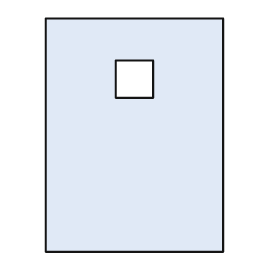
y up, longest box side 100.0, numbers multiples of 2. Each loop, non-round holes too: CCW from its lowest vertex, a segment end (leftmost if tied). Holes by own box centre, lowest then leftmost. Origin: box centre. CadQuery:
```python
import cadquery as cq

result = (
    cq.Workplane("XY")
    .moveTo(-38.0, -50.0)
    .lineTo(38.0, -50.0)
    .lineTo(38.0, 50.0)
    .lineTo(-38.0, 50.0)
    .close()
    .moveTo(-8.0, 16.0)
    .lineTo(8.0, 16.0)
    .lineTo(8.0, 32.0)
    .lineTo(-8.0, 32.0)
    .close()
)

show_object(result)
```